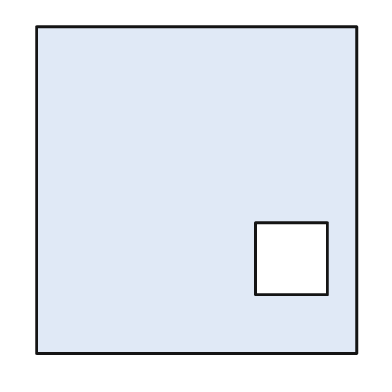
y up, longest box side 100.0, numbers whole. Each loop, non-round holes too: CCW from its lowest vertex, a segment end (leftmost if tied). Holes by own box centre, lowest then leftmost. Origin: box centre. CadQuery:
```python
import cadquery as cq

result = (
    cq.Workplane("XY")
    .moveTo(-49.0, -50.0)
    .lineTo(49.0, -50.0)
    .lineTo(49.0, 50.0)
    .lineTo(-49.0, 50.0)
    .close()
    .moveTo(18.0, -32.0)
    .lineTo(40.0, -32.0)
    .lineTo(40.0, -10.0)
    .lineTo(18.0, -10.0)
    .close()
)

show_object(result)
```